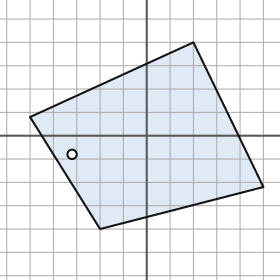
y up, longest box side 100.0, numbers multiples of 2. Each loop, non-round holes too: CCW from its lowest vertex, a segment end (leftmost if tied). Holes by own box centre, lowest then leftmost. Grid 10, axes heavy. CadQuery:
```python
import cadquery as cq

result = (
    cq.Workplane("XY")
    .moveTo(-20.0, -40.0)
    .lineTo(50.0, -22.0)
    .lineTo(20.0, 40.0)
    .lineTo(-50.0, 8.0)
    .close()
    .moveTo(-32.0, -8.0)
    .circle(2.0)
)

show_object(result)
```